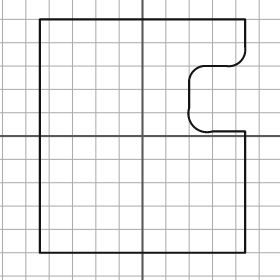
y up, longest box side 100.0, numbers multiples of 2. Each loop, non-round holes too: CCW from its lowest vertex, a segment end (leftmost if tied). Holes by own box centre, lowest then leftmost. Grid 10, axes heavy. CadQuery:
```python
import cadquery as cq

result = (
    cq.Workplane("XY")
    .moveTo(-44.0, -50.0)
    .lineTo(44.0, -50.0)
    .lineTo(44.0, 2.0)
    .lineTo(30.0, 2.0)
    .threePointArc((22.0, 4.0), (20.0, 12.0))
    .lineTo(20.0, 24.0)
    .threePointArc((22.0, 28.0), (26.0, 30.0))
    .lineTo(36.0, 30.0)
    .threePointArc((42.0, 32.0), (44.0, 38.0))
    .lineTo(44.0, 50.0)
    .lineTo(-44.0, 50.0)
    .close()
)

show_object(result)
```